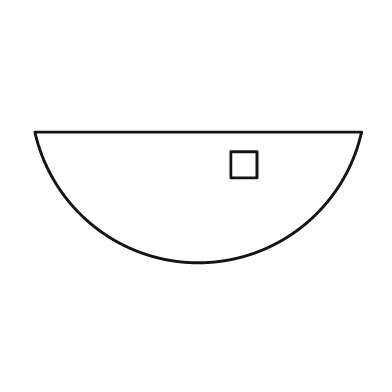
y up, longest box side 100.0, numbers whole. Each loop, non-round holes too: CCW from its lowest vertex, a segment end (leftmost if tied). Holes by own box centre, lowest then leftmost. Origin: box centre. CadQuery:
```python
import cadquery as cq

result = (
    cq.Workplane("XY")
    .moveTo(-50.0, 20.0)
    .threePointArc((0.0, -20.0), (50.0, 20.0))
    .close()
    .moveTo(10.0, 6.0)
    .lineTo(18.0, 6.0)
    .lineTo(18.0, 14.0)
    .lineTo(10.0, 14.0)
    .close()
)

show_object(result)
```